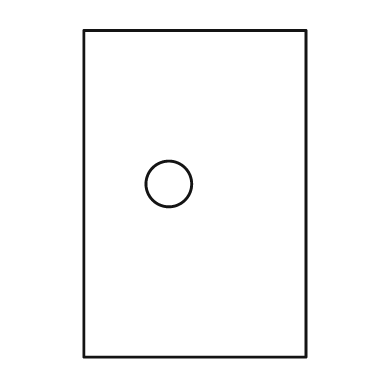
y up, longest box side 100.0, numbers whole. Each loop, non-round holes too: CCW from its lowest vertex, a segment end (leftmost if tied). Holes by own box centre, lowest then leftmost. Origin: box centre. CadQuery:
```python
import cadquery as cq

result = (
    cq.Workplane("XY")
    .moveTo(-34.0, -50.0)
    .lineTo(34.0, -50.0)
    .lineTo(34.0, 50.0)
    .lineTo(-34.0, 50.0)
    .close()
    .moveTo(-8.0, 3.0)
    .circle(7.0)
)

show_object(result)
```